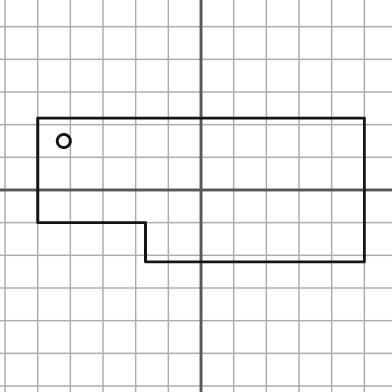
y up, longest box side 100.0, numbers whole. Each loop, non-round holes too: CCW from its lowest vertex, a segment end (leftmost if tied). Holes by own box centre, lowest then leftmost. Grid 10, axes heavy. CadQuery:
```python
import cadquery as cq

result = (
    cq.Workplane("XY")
    .moveTo(-17.0, -22.0)
    .lineTo(50.0, -22.0)
    .lineTo(50.0, 22.0)
    .lineTo(-50.0, 22.0)
    .lineTo(-50.0, -10.0)
    .lineTo(-17.0, -10.0)
    .close()
    .moveTo(-42.0, 15.0)
    .circle(2.0)
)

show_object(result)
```